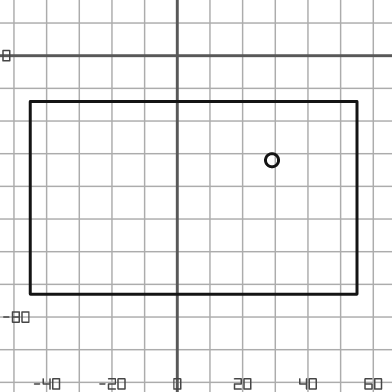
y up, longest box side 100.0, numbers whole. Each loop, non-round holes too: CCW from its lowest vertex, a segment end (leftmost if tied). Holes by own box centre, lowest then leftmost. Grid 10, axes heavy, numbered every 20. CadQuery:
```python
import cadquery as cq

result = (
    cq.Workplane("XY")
    .moveTo(-45.0, -73.0)
    .lineTo(55.0, -73.0)
    .lineTo(55.0, -14.0)
    .lineTo(-45.0, -14.0)
    .close()
    .moveTo(29.0, -32.0)
    .circle(2.0)
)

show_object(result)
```